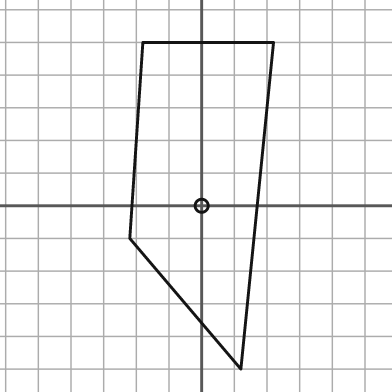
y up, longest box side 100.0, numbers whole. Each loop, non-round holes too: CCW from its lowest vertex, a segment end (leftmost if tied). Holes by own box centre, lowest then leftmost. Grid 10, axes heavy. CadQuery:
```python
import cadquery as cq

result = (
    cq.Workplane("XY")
    .moveTo(12.0, -50.0)
    .lineTo(22.0, 50.0)
    .lineTo(-18.0, 50.0)
    .lineTo(-22.0, -10.0)
    .close()
    .moveTo(0.0, 0.0)
    .circle(2.0)
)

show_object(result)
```